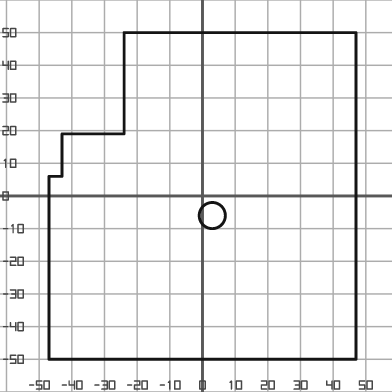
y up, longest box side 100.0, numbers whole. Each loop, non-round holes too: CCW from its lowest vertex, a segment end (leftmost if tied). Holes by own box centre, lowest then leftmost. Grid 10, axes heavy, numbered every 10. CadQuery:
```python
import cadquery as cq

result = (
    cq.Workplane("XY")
    .moveTo(-47.0, -50.0)
    .lineTo(47.0, -50.0)
    .lineTo(47.0, 50.0)
    .lineTo(-24.0, 50.0)
    .lineTo(-24.0, 19.0)
    .lineTo(-43.0, 19.0)
    .lineTo(-43.0, 6.0)
    .lineTo(-47.0, 6.0)
    .close()
    .moveTo(3.0, -6.0)
    .circle(4.0)
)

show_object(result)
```